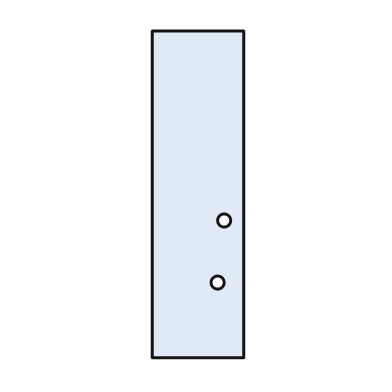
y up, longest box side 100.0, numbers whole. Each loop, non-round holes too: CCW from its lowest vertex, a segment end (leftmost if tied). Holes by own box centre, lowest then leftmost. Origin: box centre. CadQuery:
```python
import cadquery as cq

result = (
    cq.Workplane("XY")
    .moveTo(-14.0, -50.0)
    .lineTo(14.0, -50.0)
    .lineTo(14.0, 50.0)
    .lineTo(-14.0, 50.0)
    .close()
    .moveTo(6.0, -27.0)
    .circle(2.0)
    .moveTo(8.0, -8.0)
    .circle(2.0)
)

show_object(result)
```